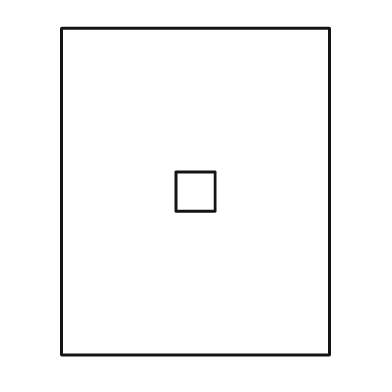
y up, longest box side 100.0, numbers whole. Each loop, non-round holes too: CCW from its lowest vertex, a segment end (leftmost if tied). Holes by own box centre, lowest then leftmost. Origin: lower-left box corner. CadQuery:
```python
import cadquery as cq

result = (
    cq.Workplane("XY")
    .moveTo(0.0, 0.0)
    .lineTo(82.0, 0.0)
    .lineTo(82.0, 100.0)
    .lineTo(0.0, 100.0)
    .close()
    .moveTo(35.0, 44.0)
    .lineTo(47.0, 44.0)
    .lineTo(47.0, 56.0)
    .lineTo(35.0, 56.0)
    .close()
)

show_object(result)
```